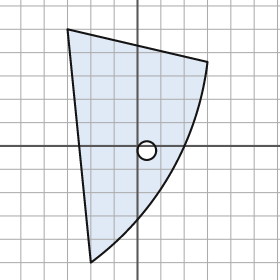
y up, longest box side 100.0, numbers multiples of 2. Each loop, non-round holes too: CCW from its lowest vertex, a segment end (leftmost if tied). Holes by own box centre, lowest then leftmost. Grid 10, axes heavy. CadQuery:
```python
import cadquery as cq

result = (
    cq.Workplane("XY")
    .moveTo(-20.0, -50.0)
    .threePointArc((14.0, -12.0), (30.0, 36.0))
    .lineTo(-30.0, 50.0)
    .close()
    .moveTo(4.0, -2.0)
    .circle(4.0)
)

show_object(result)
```